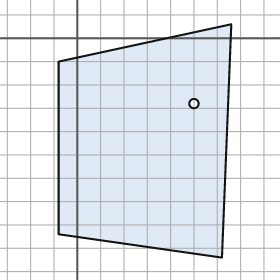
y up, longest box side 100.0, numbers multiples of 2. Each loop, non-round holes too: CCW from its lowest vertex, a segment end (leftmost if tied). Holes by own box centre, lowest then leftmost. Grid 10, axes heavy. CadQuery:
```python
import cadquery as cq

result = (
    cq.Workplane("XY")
    .moveTo(62.0, -94.0)
    .lineTo(66.0, 6.0)
    .lineTo(-8.0, -10.0)
    .lineTo(-8.0, -84.0)
    .close()
    .moveTo(50.0, -28.0)
    .circle(2.0)
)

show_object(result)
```